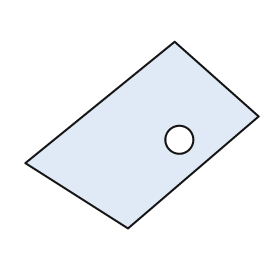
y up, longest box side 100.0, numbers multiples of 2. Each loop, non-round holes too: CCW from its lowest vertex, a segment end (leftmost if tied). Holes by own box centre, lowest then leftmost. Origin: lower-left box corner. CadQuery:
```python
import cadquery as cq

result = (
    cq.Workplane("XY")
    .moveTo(44.0, 0.0)
    .lineTo(100.0, 48.0)
    .lineTo(64.0, 80.0)
    .lineTo(0.0, 28.0)
    .close()
    .moveTo(66.0, 38.0)
    .circle(6.0)
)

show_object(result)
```